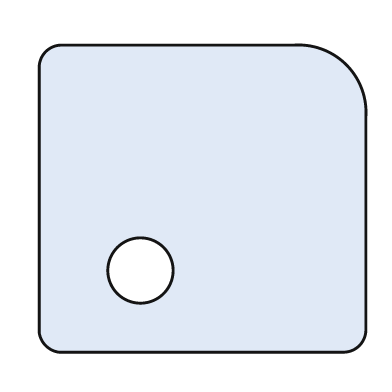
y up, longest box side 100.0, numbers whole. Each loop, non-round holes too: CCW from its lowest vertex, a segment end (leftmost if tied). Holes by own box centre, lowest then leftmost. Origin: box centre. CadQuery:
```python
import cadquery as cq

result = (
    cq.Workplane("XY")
    .moveTo(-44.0, -47.0)
    .lineTo(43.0, -47.0)
    .threePointArc((48.0, -45.0), (50.0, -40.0))
    .lineTo(50.0, 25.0)
    .threePointArc((44.0, 41.0), (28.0, 47.0))
    .lineTo(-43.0, 47.0)
    .threePointArc((-48.0, 45.0), (-50.0, 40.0))
    .lineTo(-50.0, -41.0)
    .threePointArc((-48.0, -45.0), (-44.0, -47.0))
    .close()
    .moveTo(-19.0, -22.0)
    .circle(10.0)
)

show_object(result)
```